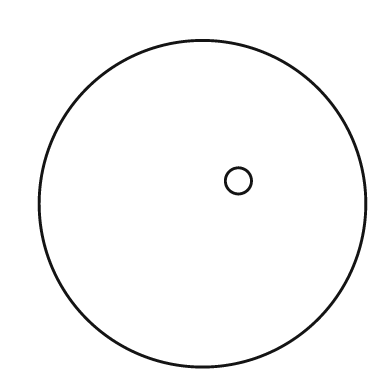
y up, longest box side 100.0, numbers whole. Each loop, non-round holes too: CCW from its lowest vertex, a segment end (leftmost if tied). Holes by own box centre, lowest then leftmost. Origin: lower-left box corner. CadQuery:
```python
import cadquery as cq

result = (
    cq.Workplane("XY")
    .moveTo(50.0, 50.0)
    .circle(50.0)
    .moveTo(61.0, 57.0)
    .circle(4.0)
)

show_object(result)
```